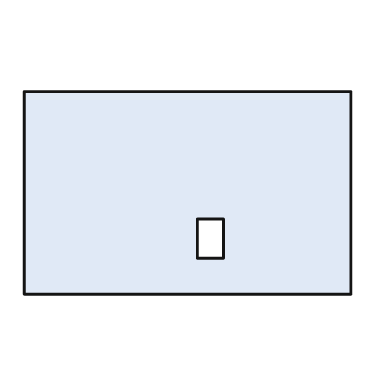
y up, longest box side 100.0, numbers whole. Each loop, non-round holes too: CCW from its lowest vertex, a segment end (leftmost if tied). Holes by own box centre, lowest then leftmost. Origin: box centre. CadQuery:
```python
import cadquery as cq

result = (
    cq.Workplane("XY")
    .moveTo(-50.0, -31.0)
    .lineTo(50.0, -31.0)
    .lineTo(50.0, 31.0)
    .lineTo(-50.0, 31.0)
    .close()
    .moveTo(3.0, -20.0)
    .lineTo(11.0, -20.0)
    .lineTo(11.0, -8.0)
    .lineTo(3.0, -8.0)
    .close()
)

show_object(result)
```